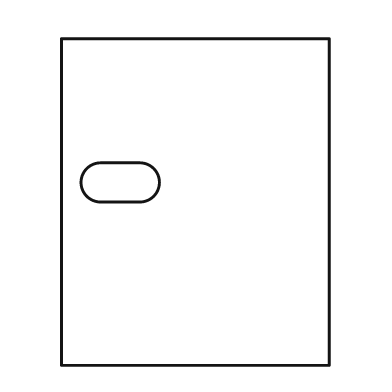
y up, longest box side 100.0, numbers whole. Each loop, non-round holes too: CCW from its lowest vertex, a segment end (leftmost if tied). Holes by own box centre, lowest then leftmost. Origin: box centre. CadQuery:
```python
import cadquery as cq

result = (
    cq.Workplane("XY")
    .moveTo(-41.0, -50.0)
    .lineTo(41.0, -50.0)
    .lineTo(41.0, 50.0)
    .lineTo(-41.0, 50.0)
    .close()
    .moveTo(-29.0, 0.0)
    .lineTo(-17.0, 0.0)
    .threePointArc((-11.0, 6.0), (-17.0, 12.0))
    .lineTo(-29.0, 12.0)
    .threePointArc((-35.0, 6.0), (-29.0, 0.0))
    .close()
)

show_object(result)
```